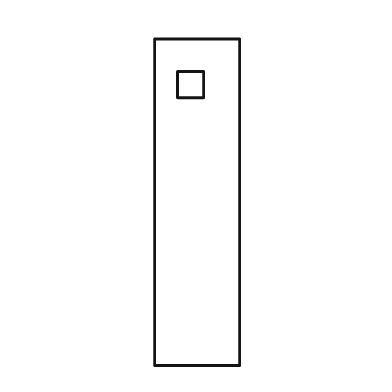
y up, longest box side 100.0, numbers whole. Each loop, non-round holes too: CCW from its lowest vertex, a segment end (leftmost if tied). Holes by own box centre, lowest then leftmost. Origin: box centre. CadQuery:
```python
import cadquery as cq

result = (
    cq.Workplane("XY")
    .moveTo(-13.0, -50.0)
    .lineTo(13.0, -50.0)
    .lineTo(13.0, 50.0)
    .lineTo(-13.0, 50.0)
    .close()
    .moveTo(-6.0, 32.0)
    .lineTo(2.0, 32.0)
    .lineTo(2.0, 40.0)
    .lineTo(-6.0, 40.0)
    .close()
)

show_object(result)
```